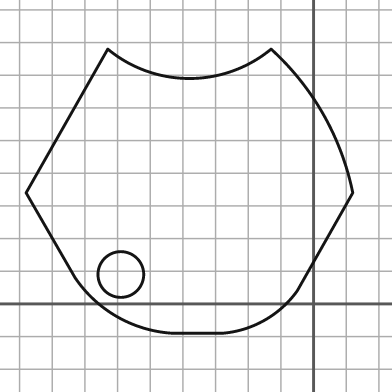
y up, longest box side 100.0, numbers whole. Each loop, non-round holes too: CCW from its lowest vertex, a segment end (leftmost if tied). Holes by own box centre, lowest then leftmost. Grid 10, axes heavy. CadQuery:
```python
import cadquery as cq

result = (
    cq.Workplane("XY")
    .moveTo(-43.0, -9.0)
    .lineTo(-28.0, -9.0)
    .threePointArc((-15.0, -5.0), (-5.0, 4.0))
    .lineTo(12.0, 34.0)
    .threePointArc((3.0, 58.0), (-13.0, 78.0))
    .threePointArc((-38.0, 69.0), (-63.0, 78.0))
    .lineTo(-88.0, 34.0)
    .lineTo(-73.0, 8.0)
    .threePointArc((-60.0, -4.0), (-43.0, -9.0))
    .close()
    .moveTo(-59.0, 9.0)
    .circle(7.0)
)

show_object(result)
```